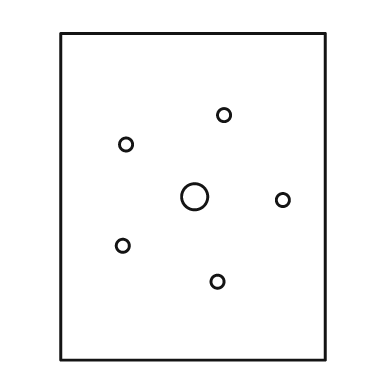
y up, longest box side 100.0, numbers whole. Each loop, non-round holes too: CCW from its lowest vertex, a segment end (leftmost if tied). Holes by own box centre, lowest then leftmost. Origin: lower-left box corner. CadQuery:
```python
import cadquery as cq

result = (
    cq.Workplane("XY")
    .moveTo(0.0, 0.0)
    .lineTo(81.0, 0.0)
    .lineTo(81.0, 100.0)
    .lineTo(0.0, 100.0)
    .close()
    .moveTo(48.0, 24.0)
    .circle(2.0)
    .moveTo(19.0, 35.0)
    .circle(2.0)
    .moveTo(68.0, 49.0)
    .circle(2.0)
    .moveTo(41.0, 50.0)
    .circle(4.0)
    .moveTo(20.0, 66.0)
    .circle(2.0)
    .moveTo(50.0, 75.0)
    .circle(2.0)
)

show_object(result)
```